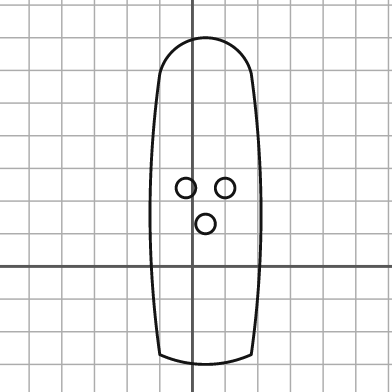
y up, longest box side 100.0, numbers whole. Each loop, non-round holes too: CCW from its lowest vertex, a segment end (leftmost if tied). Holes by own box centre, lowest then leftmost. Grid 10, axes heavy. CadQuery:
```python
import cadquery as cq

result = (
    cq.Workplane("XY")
    .moveTo(-10.0, -27.0)
    .threePointArc((4.0, -30.0), (18.0, -27.0))
    .threePointArc((21.0, 16.0), (18.0, 59.0))
    .threePointArc((4.0, 70.0), (-10.0, 59.0))
    .threePointArc((-13.0, 16.0), (-10.0, -27.0))
    .close()
    .moveTo(4.0, 13.0)
    .circle(3.0)
    .moveTo(-2.0, 24.0)
    .circle(3.0)
    .moveTo(10.0, 24.0)
    .circle(3.0)
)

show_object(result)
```